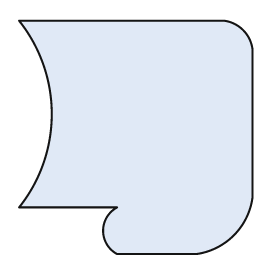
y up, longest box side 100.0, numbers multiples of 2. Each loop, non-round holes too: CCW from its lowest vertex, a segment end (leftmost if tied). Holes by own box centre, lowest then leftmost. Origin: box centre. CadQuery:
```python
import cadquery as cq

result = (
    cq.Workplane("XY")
    .moveTo(-8.0, -50.0)
    .lineTo(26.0, -50.0)
    .threePointArc((42.0, -42.0), (50.0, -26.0))
    .lineTo(50.0, 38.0)
    .threePointArc((46.0, 46.0), (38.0, 50.0))
    .lineTo(-50.0, 50.0)
    .threePointArc((-36.0, 10.0), (-50.0, -30.0))
    .lineTo(-8.0, -30.0)
    .threePointArc((-14.0, -40.0), (-8.0, -50.0))
    .close()
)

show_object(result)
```